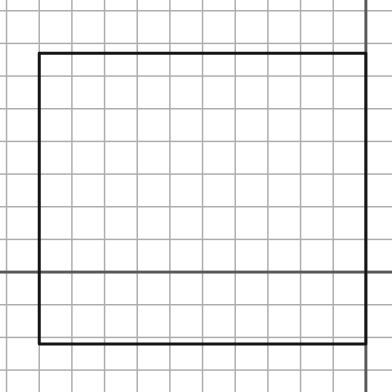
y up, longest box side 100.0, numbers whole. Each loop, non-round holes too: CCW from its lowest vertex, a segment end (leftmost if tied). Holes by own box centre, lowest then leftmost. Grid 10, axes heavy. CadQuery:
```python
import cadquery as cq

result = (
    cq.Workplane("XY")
    .moveTo(-100.0, -22.0)
    .lineTo(0.0, -22.0)
    .lineTo(0.0, 67.0)
    .lineTo(-100.0, 67.0)
    .close()
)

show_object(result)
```